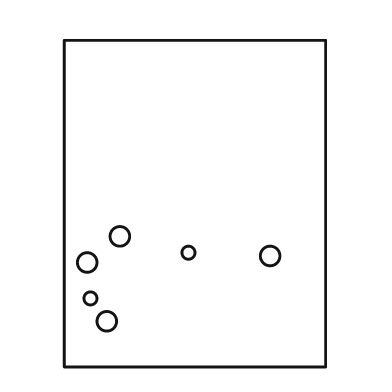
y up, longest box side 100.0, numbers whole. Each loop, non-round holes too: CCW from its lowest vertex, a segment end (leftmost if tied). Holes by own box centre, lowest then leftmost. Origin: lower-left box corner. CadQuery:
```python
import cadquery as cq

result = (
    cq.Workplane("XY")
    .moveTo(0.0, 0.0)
    .lineTo(80.0, 0.0)
    .lineTo(80.0, 100.0)
    .lineTo(0.0, 100.0)
    .close()
    .moveTo(13.0, 14.0)
    .circle(3.0)
    .moveTo(8.0, 21.0)
    .circle(2.0)
    .moveTo(7.0, 32.0)
    .circle(3.0)
    .moveTo(63.0, 34.0)
    .circle(3.0)
    .moveTo(38.0, 35.0)
    .circle(2.0)
    .moveTo(17.0, 40.0)
    .circle(3.0)
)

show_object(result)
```